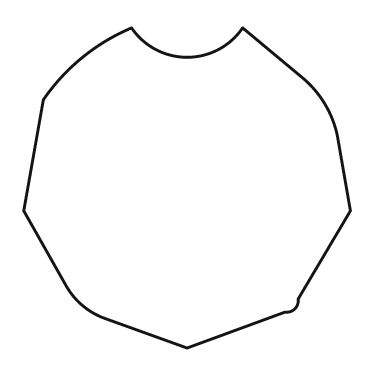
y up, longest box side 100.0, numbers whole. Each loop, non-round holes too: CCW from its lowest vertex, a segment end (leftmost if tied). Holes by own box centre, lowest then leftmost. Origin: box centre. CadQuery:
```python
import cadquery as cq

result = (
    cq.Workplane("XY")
    .moveTo(0.0, -49.0)
    .lineTo(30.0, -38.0)
    .threePointArc((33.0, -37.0), (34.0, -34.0))
    .lineTo(50.0, -7.0)
    .lineTo(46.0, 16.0)
    .threePointArc((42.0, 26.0), (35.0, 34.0))
    .lineTo(17.0, 49.0)
    .threePointArc((0.0, 40.0), (-17.0, 49.0))
    .threePointArc((-32.0, 40.0), (-44.0, 27.0))
    .lineTo(-50.0, -7.0)
    .lineTo(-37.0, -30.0)
    .threePointArc((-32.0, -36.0), (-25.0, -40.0))
    .close()
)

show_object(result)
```